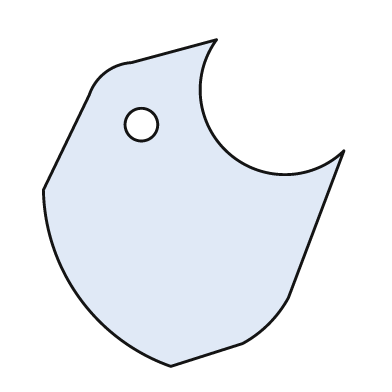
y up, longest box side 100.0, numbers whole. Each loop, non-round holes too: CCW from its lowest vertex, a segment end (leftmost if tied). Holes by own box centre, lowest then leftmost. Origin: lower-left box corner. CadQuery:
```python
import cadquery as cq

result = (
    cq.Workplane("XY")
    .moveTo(39.0, 0.0)
    .lineTo(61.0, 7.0)
    .threePointArc((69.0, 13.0), (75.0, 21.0))
    .lineTo(92.0, 66.0)
    .threePointArc((57.0, 65.0), (53.0, 100.0))
    .lineTo(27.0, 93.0)
    .threePointArc((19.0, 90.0), (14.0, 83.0))
    .lineTo(0.0, 54.0)
    .threePointArc((11.0, 21.0), (39.0, 0.0))
    .close()
    .moveTo(30.0, 74.0)
    .circle(5.0)
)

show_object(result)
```